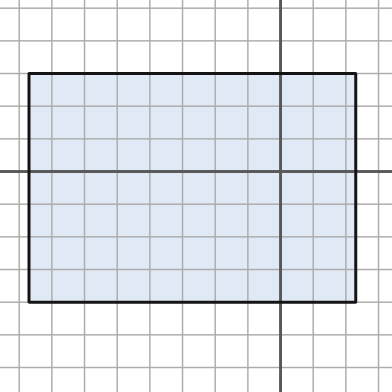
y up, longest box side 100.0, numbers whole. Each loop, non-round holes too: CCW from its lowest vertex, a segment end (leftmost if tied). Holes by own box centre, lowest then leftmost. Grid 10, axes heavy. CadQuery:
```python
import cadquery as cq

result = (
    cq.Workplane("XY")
    .moveTo(-77.0, -40.0)
    .lineTo(23.0, -40.0)
    .lineTo(23.0, 30.0)
    .lineTo(-77.0, 30.0)
    .close()
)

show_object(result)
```